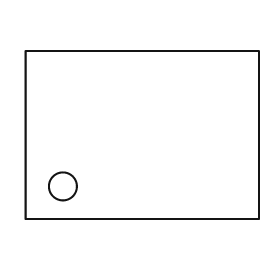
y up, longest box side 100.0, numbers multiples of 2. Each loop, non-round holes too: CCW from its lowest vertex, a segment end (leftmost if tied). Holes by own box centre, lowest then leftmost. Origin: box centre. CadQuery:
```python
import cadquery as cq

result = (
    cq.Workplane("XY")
    .moveTo(-50.0, -36.0)
    .lineTo(50.0, -36.0)
    .lineTo(50.0, 36.0)
    .lineTo(-50.0, 36.0)
    .close()
    .moveTo(-34.0, -22.0)
    .circle(6.0)
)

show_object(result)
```